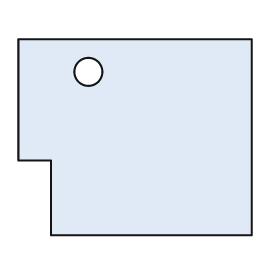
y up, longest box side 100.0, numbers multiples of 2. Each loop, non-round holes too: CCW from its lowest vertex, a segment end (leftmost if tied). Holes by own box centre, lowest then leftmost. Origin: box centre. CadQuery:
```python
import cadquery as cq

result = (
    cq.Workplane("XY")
    .moveTo(-36.0, -42.0)
    .lineTo(50.0, -42.0)
    .lineTo(50.0, 42.0)
    .lineTo(-50.0, 42.0)
    .lineTo(-50.0, -10.0)
    .lineTo(-36.0, -10.0)
    .close()
    .moveTo(-20.0, 28.0)
    .circle(6.0)
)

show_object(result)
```